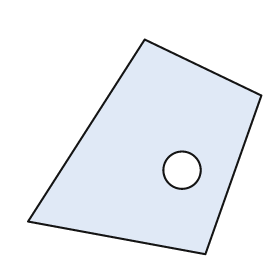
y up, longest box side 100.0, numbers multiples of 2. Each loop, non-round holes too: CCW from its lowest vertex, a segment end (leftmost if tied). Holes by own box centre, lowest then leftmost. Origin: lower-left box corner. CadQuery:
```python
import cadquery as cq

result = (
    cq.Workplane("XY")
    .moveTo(76.0, 0.0)
    .lineTo(100.0, 68.0)
    .lineTo(50.0, 92.0)
    .lineTo(0.0, 14.0)
    .close()
    .moveTo(66.0, 36.0)
    .circle(8.0)
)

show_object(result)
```